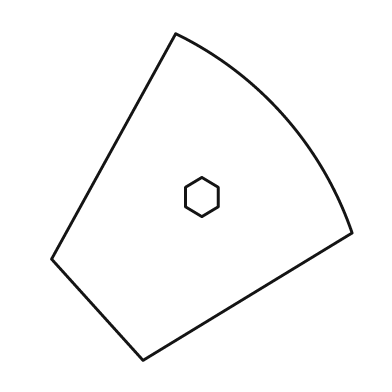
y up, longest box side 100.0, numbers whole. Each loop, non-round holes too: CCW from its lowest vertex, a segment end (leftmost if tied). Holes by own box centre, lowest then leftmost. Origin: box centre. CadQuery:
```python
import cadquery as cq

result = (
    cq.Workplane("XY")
    .moveTo(-18.0, -50.0)
    .lineTo(46.0, -11.0)
    .threePointArc((25.0, 25.0), (-8.0, 50.0))
    .lineTo(-46.0, -19.0)
    .close()
    .moveTo(0.0, -6.0)
    .lineTo(5.0, -3.0)
    .lineTo(5.0, 3.0)
    .lineTo(0.0, 6.0)
    .lineTo(-5.0, 3.0)
    .lineTo(-5.0, -3.0)
    .close()
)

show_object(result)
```